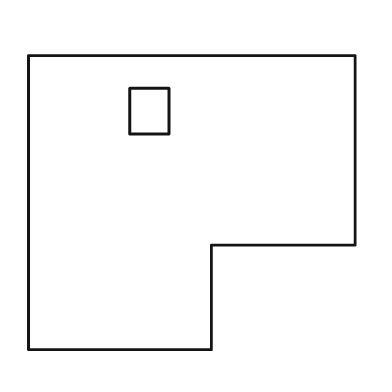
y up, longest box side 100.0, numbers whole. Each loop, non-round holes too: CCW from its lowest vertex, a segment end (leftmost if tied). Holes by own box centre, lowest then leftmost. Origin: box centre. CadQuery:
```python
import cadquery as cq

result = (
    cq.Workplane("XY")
    .moveTo(-50.0, -45.0)
    .lineTo(6.0, -45.0)
    .lineTo(6.0, -13.0)
    .lineTo(50.0, -13.0)
    .lineTo(50.0, 45.0)
    .lineTo(-50.0, 45.0)
    .close()
    .moveTo(-19.0, 21.0)
    .lineTo(-7.0, 21.0)
    .lineTo(-7.0, 35.0)
    .lineTo(-19.0, 35.0)
    .close()
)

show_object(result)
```